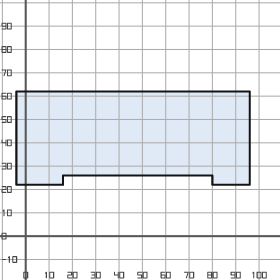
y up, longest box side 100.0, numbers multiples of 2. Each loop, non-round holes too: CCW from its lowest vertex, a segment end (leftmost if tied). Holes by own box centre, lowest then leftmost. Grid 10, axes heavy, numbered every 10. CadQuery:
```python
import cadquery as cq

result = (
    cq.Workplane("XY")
    .moveTo(-4.0, 22.0)
    .lineTo(16.0, 22.0)
    .lineTo(16.0, 26.0)
    .lineTo(80.0, 26.0)
    .lineTo(80.0, 22.0)
    .lineTo(96.0, 22.0)
    .lineTo(96.0, 62.0)
    .lineTo(-4.0, 62.0)
    .close()
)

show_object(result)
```